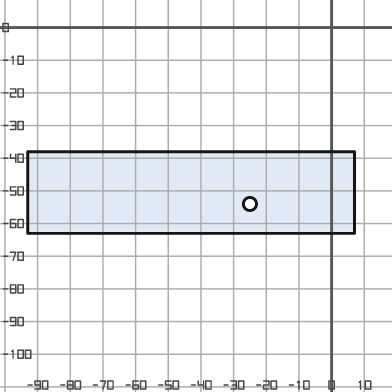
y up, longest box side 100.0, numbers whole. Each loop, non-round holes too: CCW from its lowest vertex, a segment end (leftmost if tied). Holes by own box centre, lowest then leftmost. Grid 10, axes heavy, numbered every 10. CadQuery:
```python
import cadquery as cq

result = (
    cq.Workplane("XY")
    .moveTo(-93.0, -63.0)
    .lineTo(7.0, -63.0)
    .lineTo(7.0, -38.0)
    .lineTo(-93.0, -38.0)
    .close()
    .moveTo(-25.0, -54.0)
    .circle(2.0)
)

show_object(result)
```